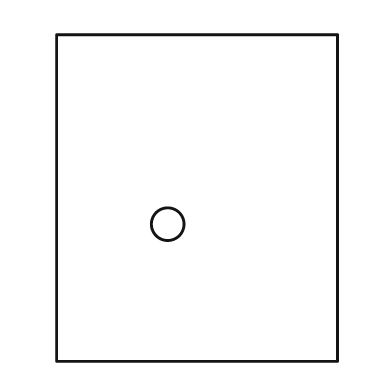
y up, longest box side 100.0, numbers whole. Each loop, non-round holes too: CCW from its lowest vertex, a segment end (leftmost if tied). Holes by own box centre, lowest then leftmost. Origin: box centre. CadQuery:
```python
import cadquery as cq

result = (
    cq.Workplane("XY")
    .moveTo(-43.0, -50.0)
    .lineTo(43.0, -50.0)
    .lineTo(43.0, 50.0)
    .lineTo(-43.0, 50.0)
    .close()
    .moveTo(-9.0, -8.0)
    .circle(5.0)
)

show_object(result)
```